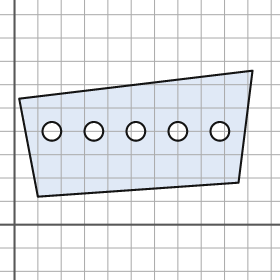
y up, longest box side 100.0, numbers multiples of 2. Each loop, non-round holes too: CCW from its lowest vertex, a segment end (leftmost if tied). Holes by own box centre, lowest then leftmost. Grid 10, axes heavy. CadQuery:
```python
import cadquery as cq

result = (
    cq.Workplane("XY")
    .moveTo(10.0, 12.0)
    .lineTo(96.0, 18.0)
    .lineTo(102.0, 66.0)
    .lineTo(2.0, 54.0)
    .close()
    .moveTo(16.0, 40.0)
    .circle(4.0)
    .moveTo(34.0, 40.0)
    .circle(4.0)
    .moveTo(52.0, 40.0)
    .circle(4.0)
    .moveTo(70.0, 40.0)
    .circle(4.0)
    .moveTo(88.0, 40.0)
    .circle(4.0)
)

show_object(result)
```